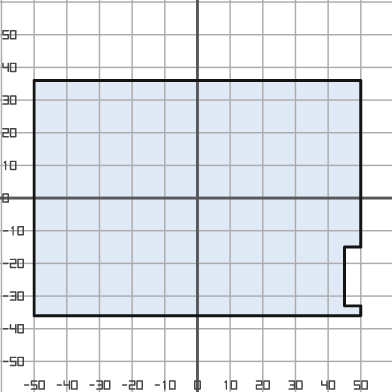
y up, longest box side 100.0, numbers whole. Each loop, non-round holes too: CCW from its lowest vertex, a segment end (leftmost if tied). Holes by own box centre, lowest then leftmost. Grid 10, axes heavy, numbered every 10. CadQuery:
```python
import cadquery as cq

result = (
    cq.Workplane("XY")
    .moveTo(-50.0, -36.0)
    .lineTo(50.0, -36.0)
    .lineTo(50.0, -33.0)
    .lineTo(45.0, -33.0)
    .lineTo(45.0, -15.0)
    .lineTo(50.0, -15.0)
    .lineTo(50.0, 36.0)
    .lineTo(-50.0, 36.0)
    .close()
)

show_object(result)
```